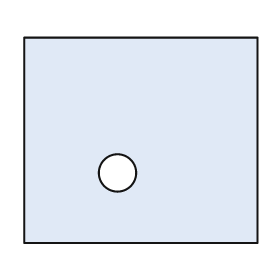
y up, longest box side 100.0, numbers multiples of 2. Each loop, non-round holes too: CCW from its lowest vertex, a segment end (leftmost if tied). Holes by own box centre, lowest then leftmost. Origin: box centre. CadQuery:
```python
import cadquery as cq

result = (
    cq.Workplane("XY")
    .moveTo(-50.0, -44.0)
    .lineTo(50.0, -44.0)
    .lineTo(50.0, 44.0)
    .lineTo(-50.0, 44.0)
    .close()
    .moveTo(-10.0, -14.0)
    .circle(8.0)
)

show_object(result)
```